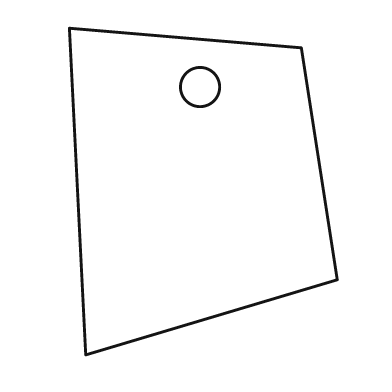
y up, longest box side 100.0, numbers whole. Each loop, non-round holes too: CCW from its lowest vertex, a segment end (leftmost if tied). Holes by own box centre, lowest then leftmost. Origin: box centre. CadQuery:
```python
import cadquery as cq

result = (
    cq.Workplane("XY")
    .moveTo(-36.0, -50.0)
    .lineTo(41.0, -27.0)
    .lineTo(30.0, 44.0)
    .lineTo(-41.0, 50.0)
    .close()
    .moveTo(-1.0, 32.0)
    .circle(6.0)
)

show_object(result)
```